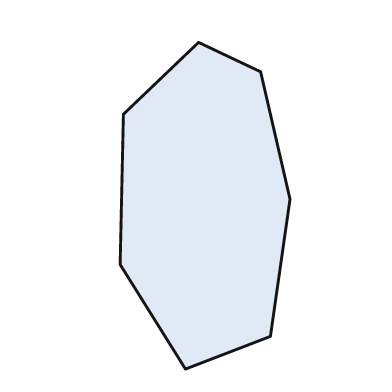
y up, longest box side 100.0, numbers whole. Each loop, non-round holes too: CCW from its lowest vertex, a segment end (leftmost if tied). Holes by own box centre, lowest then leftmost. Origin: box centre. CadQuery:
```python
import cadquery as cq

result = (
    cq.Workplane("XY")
    .moveTo(-6.0, -50.0)
    .lineTo(20.0, -40.0)
    .lineTo(26.0, 2.0)
    .lineTo(17.0, 41.0)
    .lineTo(-2.0, 50.0)
    .lineTo(-25.0, 28.0)
    .lineTo(-26.0, -18.0)
    .close()
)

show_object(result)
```